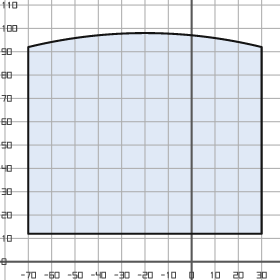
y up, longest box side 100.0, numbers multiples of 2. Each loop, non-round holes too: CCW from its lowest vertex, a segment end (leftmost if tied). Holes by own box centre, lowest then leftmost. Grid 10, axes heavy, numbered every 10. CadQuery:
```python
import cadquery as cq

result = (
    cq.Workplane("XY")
    .moveTo(-70.0, 12.0)
    .lineTo(30.0, 12.0)
    .lineTo(30.0, 92.0)
    .threePointArc((-20.0, 98.0), (-70.0, 92.0))
    .close()
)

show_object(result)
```